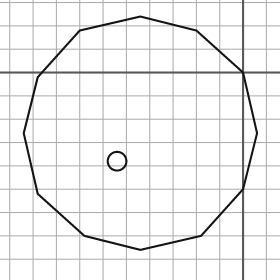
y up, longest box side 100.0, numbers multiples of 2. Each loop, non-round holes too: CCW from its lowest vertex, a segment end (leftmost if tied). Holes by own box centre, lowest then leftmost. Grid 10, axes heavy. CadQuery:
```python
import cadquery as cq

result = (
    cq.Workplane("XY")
    .moveTo(-44.0, -76.0)
    .lineTo(-18.0, -70.0)
    .lineTo(0.0, -50.0)
    .lineTo(6.0, -26.0)
    .lineTo(0.0, 0.0)
    .lineTo(-20.0, 18.0)
    .lineTo(-44.0, 24.0)
    .lineTo(-70.0, 18.0)
    .lineTo(-88.0, -2.0)
    .lineTo(-94.0, -26.0)
    .lineTo(-88.0, -52.0)
    .lineTo(-68.0, -70.0)
    .close()
    .moveTo(-54.0, -38.0)
    .circle(4.0)
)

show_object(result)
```